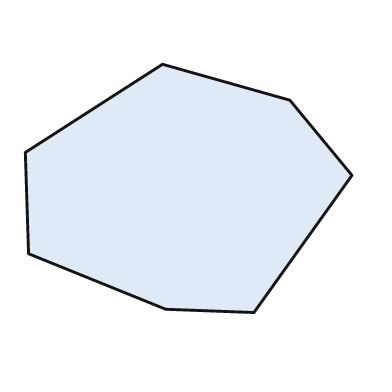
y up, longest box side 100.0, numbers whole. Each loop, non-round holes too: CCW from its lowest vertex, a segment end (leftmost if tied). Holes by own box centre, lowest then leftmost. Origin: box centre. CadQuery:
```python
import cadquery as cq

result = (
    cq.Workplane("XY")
    .moveTo(20.0, -38.0)
    .lineTo(50.0, 4.0)
    .lineTo(31.0, 27.0)
    .lineTo(-8.0, 38.0)
    .lineTo(-50.0, 11.0)
    .lineTo(-49.0, -20.0)
    .lineTo(-7.0, -37.0)
    .close()
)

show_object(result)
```